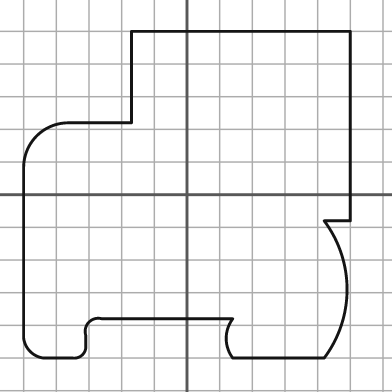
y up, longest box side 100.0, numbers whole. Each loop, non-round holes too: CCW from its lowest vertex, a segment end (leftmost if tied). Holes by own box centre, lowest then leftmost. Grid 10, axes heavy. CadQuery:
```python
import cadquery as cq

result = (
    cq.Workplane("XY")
    .moveTo(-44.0, -50.0)
    .lineTo(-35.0, -50.0)
    .threePointArc((-32.0, -49.0), (-31.0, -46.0))
    .lineTo(-31.0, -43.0)
    .threePointArc((-30.0, -39.0), (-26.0, -38.0))
    .lineTo(14.0, -38.0)
    .threePointArc((12.0, -44.0), (14.0, -50.0))
    .lineTo(42.0, -50.0)
    .threePointArc((49.0, -29.0), (42.0, -8.0))
    .lineTo(50.0, -8.0)
    .lineTo(50.0, 50.0)
    .lineTo(-17.0, 50.0)
    .lineTo(-17.0, 22.0)
    .lineTo(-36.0, 22.0)
    .threePointArc((-46.0, 18.0), (-50.0, 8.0))
    .lineTo(-50.0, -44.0)
    .threePointArc((-48.0, -48.0), (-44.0, -50.0))
    .close()
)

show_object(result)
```